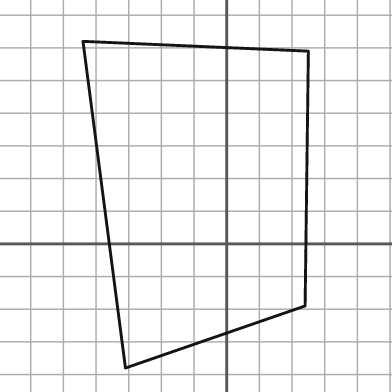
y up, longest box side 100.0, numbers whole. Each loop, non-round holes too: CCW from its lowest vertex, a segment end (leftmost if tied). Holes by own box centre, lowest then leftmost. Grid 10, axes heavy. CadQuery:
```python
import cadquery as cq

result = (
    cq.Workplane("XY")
    .moveTo(-31.0, -38.0)
    .lineTo(24.0, -19.0)
    .lineTo(25.0, 59.0)
    .lineTo(-44.0, 62.0)
    .close()
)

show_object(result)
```